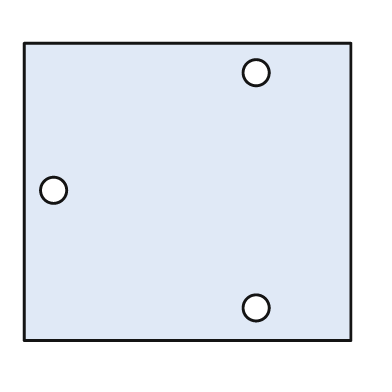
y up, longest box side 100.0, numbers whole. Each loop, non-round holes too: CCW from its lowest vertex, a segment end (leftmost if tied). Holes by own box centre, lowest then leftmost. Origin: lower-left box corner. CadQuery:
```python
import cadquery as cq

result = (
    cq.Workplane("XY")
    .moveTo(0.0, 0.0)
    .lineTo(100.0, 0.0)
    .lineTo(100.0, 91.0)
    .lineTo(0.0, 91.0)
    .close()
    .moveTo(71.0, 10.0)
    .circle(4.0)
    .moveTo(9.0, 46.0)
    .circle(4.0)
    .moveTo(71.0, 82.0)
    .circle(4.0)
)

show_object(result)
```